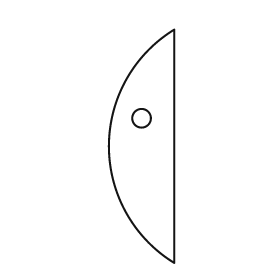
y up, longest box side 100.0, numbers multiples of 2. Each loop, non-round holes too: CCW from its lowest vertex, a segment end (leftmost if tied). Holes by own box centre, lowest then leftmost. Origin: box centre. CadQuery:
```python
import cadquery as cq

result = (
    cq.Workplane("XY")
    .moveTo(14.0, -50.0)
    .lineTo(14.0, 50.0)
    .threePointArc((-14.0, 0.0), (14.0, -50.0))
    .close()
    .moveTo(0.0, 12.0)
    .circle(4.0)
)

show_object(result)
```